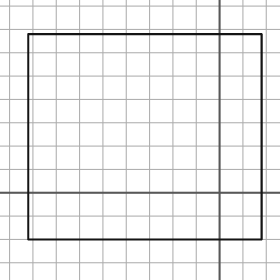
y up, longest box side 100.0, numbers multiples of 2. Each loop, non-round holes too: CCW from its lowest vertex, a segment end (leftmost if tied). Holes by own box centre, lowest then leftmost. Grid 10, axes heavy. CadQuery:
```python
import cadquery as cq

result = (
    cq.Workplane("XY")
    .moveTo(-82.0, -20.0)
    .lineTo(18.0, -20.0)
    .lineTo(18.0, 68.0)
    .lineTo(-82.0, 68.0)
    .close()
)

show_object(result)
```